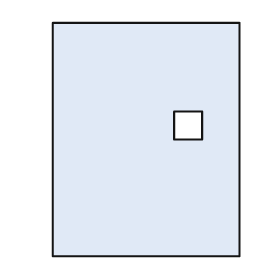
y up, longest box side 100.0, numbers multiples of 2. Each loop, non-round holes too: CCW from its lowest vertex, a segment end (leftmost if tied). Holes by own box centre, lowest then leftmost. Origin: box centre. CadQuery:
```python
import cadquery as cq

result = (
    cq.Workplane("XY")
    .moveTo(-40.0, -50.0)
    .lineTo(40.0, -50.0)
    .lineTo(40.0, 50.0)
    .lineTo(-40.0, 50.0)
    .close()
    .moveTo(12.0, 0.0)
    .lineTo(24.0, 0.0)
    .lineTo(24.0, 12.0)
    .lineTo(12.0, 12.0)
    .close()
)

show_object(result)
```